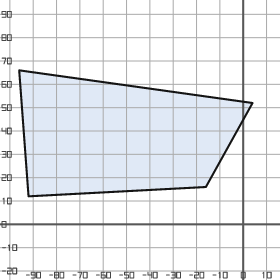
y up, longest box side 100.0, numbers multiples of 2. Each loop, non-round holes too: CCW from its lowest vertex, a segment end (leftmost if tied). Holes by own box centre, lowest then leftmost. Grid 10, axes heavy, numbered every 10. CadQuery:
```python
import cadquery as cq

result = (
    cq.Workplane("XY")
    .moveTo(-92.0, 12.0)
    .lineTo(-16.0, 16.0)
    .lineTo(4.0, 52.0)
    .lineTo(-96.0, 66.0)
    .close()
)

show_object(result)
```